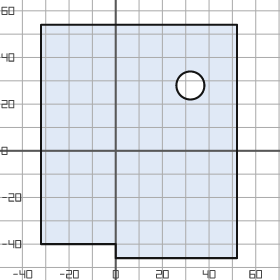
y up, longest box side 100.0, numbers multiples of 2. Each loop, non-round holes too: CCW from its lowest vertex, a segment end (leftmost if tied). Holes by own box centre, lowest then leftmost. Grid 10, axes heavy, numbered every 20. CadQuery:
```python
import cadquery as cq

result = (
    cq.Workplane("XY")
    .moveTo(0.0, -46.0)
    .lineTo(52.0, -46.0)
    .lineTo(52.0, 54.0)
    .lineTo(-32.0, 54.0)
    .lineTo(-32.0, -40.0)
    .lineTo(0.0, -40.0)
    .close()
    .moveTo(32.0, 28.0)
    .circle(6.0)
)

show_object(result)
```